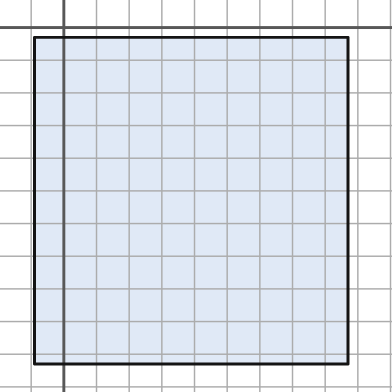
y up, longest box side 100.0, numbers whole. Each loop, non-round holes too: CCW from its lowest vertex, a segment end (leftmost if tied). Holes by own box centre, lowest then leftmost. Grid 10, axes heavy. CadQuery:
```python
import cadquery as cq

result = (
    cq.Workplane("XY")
    .moveTo(-9.0, -103.0)
    .lineTo(87.0, -103.0)
    .lineTo(87.0, -3.0)
    .lineTo(-9.0, -3.0)
    .close()
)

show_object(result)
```